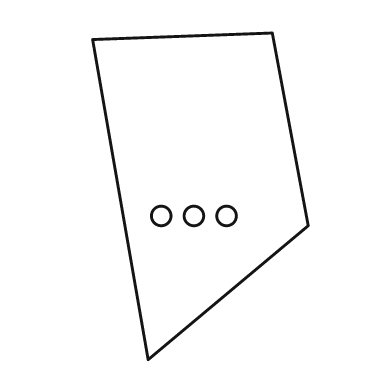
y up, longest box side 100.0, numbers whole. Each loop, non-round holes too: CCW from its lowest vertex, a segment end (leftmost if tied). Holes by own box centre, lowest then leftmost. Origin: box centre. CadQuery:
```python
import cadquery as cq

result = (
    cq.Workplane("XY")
    .moveTo(-16.0, -50.0)
    .lineTo(33.0, -9.0)
    .lineTo(22.0, 50.0)
    .lineTo(-33.0, 48.0)
    .close()
    .moveTo(-12.0, -6.0)
    .circle(3.0)
    .moveTo(-2.0, -6.0)
    .circle(3.0)
    .moveTo(8.0, -6.0)
    .circle(3.0)
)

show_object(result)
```